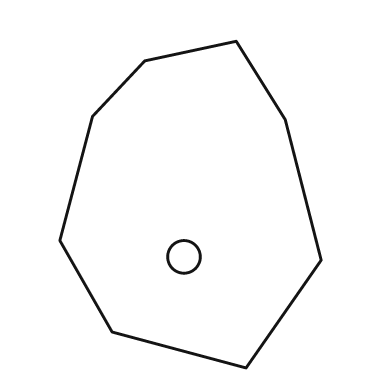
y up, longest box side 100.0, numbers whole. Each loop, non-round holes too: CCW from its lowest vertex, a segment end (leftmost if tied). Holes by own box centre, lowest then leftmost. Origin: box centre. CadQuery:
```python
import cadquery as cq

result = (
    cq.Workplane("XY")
    .moveTo(17.0, -50.0)
    .lineTo(40.0, -17.0)
    .lineTo(29.0, 26.0)
    .lineTo(14.0, 50.0)
    .lineTo(-14.0, 44.0)
    .lineTo(-30.0, 27.0)
    .lineTo(-40.0, -11.0)
    .lineTo(-24.0, -39.0)
    .close()
    .moveTo(-2.0, -16.0)
    .circle(5.0)
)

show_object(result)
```